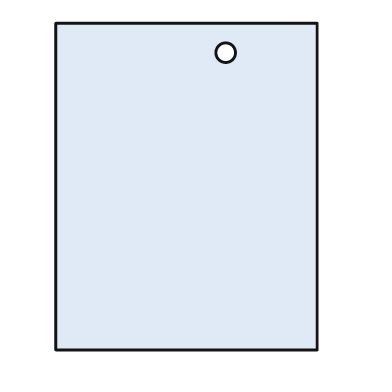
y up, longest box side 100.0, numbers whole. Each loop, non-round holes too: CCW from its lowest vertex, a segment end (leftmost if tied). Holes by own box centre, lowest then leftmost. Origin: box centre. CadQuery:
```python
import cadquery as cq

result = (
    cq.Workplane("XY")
    .moveTo(-40.0, -50.0)
    .lineTo(40.0, -50.0)
    .lineTo(40.0, 50.0)
    .lineTo(-40.0, 50.0)
    .close()
    .moveTo(12.0, 41.0)
    .circle(3.0)
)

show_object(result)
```